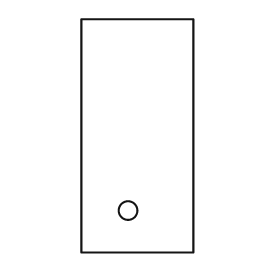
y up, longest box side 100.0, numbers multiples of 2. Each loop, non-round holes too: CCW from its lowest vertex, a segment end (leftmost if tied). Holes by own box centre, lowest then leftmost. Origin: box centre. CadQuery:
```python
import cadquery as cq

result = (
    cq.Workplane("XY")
    .moveTo(-24.0, -50.0)
    .lineTo(24.0, -50.0)
    .lineTo(24.0, 50.0)
    .lineTo(-24.0, 50.0)
    .close()
    .moveTo(-4.0, -32.0)
    .circle(4.0)
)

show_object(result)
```